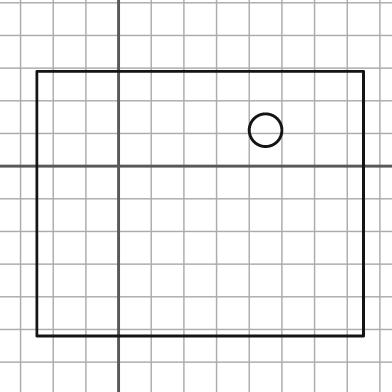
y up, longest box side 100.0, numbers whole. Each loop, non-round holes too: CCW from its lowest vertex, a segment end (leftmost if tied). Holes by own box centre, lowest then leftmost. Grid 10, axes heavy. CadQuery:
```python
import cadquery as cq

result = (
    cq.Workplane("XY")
    .moveTo(-25.0, -52.0)
    .lineTo(75.0, -52.0)
    .lineTo(75.0, 29.0)
    .lineTo(-25.0, 29.0)
    .close()
    .moveTo(45.0, 11.0)
    .circle(5.0)
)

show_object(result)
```